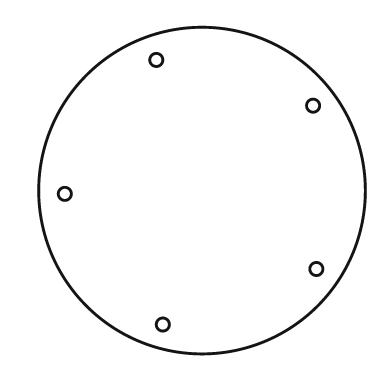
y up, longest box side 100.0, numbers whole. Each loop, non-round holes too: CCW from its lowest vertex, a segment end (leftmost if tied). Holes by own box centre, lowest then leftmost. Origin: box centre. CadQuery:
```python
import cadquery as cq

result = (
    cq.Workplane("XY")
    .moveTo(0.0, 0.0)
    .circle(50.0)
    .moveTo(-12.0, -41.0)
    .circle(2.0)
    .moveTo(35.0, -24.0)
    .circle(2.0)
    .moveTo(-42.0, -1.0)
    .circle(2.0)
    .moveTo(34.0, 26.0)
    .circle(2.0)
    .moveTo(-14.0, 40.0)
    .circle(2.0)
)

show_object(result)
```